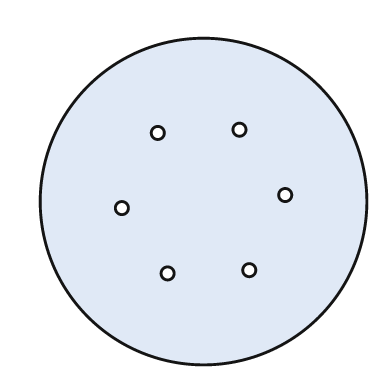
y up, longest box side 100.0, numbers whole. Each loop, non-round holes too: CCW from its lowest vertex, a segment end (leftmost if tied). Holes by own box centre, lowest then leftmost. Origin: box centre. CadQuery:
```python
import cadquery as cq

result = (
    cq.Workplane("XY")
    .moveTo(0.0, 0.0)
    .circle(50.0)
    .moveTo(-11.0, -22.0)
    .circle(2.0)
    .moveTo(14.0, -21.0)
    .circle(2.0)
    .moveTo(-25.0, -2.0)
    .circle(2.0)
    .moveTo(25.0, 2.0)
    .circle(2.0)
    .moveTo(-14.0, 21.0)
    .circle(2.0)
    .moveTo(11.0, 22.0)
    .circle(2.0)
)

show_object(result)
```